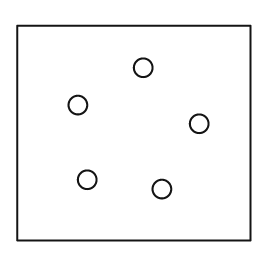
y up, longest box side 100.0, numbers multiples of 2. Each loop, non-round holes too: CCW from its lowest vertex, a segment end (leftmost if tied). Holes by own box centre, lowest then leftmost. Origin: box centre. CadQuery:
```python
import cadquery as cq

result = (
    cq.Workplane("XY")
    .moveTo(-50.0, -46.0)
    .lineTo(50.0, -46.0)
    .lineTo(50.0, 46.0)
    .lineTo(-50.0, 46.0)
    .close()
    .moveTo(12.0, -24.0)
    .circle(4.0)
    .moveTo(-20.0, -20.0)
    .circle(4.0)
    .moveTo(28.0, 4.0)
    .circle(4.0)
    .moveTo(-24.0, 12.0)
    .circle(4.0)
    .moveTo(4.0, 28.0)
    .circle(4.0)
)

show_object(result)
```